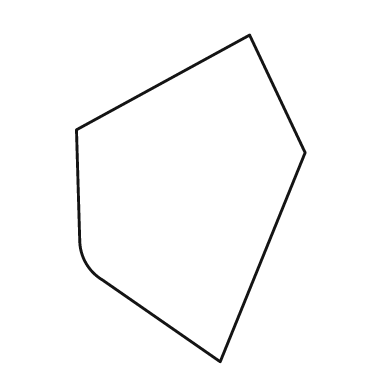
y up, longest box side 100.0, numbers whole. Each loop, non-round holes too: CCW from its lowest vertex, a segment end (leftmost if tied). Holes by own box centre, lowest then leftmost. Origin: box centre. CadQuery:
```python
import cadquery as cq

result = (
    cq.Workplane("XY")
    .moveTo(9.0, -50.0)
    .lineTo(35.0, 14.0)
    .lineTo(18.0, 50.0)
    .lineTo(-35.0, 21.0)
    .lineTo(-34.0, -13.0)
    .threePointArc((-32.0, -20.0), (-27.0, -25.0))
    .close()
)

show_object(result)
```